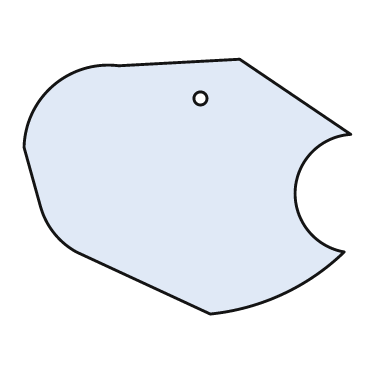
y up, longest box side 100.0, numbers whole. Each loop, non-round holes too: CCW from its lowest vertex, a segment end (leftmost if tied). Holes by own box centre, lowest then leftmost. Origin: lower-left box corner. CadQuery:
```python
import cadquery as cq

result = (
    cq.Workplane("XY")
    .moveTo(57.0, 0.0)
    .threePointArc((79.0, 6.0), (98.0, 19.0))
    .threePointArc((83.0, 38.0), (100.0, 55.0))
    .lineTo(66.0, 78.0)
    .lineTo(29.0, 76.0)
    .threePointArc((9.0, 70.0), (0.0, 51.0))
    .lineTo(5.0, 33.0)
    .threePointArc((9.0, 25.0), (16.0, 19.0))
    .close()
    .moveTo(54.0, 66.0)
    .circle(2.0)
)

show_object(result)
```